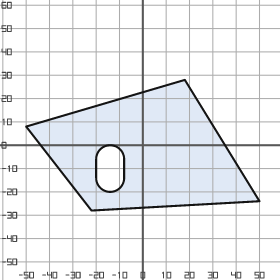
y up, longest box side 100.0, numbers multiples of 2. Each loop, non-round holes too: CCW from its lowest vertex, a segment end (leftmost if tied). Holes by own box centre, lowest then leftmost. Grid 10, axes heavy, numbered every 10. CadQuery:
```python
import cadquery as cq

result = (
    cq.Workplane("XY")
    .moveTo(-22.0, -28.0)
    .lineTo(50.0, -24.0)
    .lineTo(18.0, 28.0)
    .lineTo(-50.0, 8.0)
    .close()
    .moveTo(-20.0, -14.0)
    .threePointArc((-14.0, -20.0), (-8.0, -14.0))
    .lineTo(-8.0, -6.0)
    .threePointArc((-14.0, 0.0), (-20.0, -6.0))
    .close()
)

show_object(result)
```